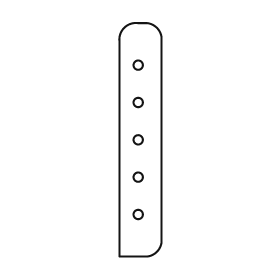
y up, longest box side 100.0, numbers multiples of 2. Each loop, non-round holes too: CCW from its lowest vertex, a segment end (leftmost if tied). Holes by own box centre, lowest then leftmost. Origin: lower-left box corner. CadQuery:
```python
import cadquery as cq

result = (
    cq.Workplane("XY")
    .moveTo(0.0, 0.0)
    .lineTo(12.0, 0.0)
    .threePointArc((16.0, 2.0), (18.0, 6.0))
    .lineTo(18.0, 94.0)
    .threePointArc((16.0, 98.0), (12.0, 100.0))
    .lineTo(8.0, 100.0)
    .threePointArc((2.0, 98.0), (0.0, 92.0))
    .close()
    .moveTo(8.0, 18.0)
    .circle(2.0)
    .moveTo(8.0, 34.0)
    .circle(2.0)
    .moveTo(8.0, 50.0)
    .circle(2.0)
    .moveTo(8.0, 66.0)
    .circle(2.0)
    .moveTo(8.0, 82.0)
    .circle(2.0)
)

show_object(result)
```